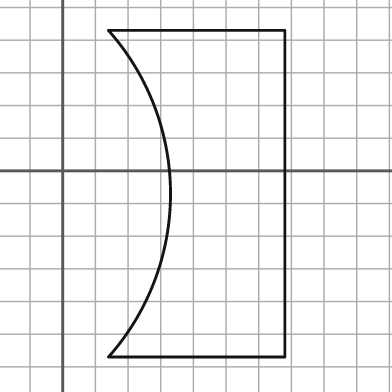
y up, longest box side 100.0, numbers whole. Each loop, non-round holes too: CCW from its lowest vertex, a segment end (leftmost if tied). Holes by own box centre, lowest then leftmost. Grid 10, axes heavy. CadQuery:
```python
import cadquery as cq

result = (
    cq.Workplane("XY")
    .moveTo(14.0, -57.0)
    .lineTo(68.0, -57.0)
    .lineTo(68.0, 43.0)
    .lineTo(14.0, 43.0)
    .threePointArc((33.0, -7.0), (14.0, -57.0))
    .close()
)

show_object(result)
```